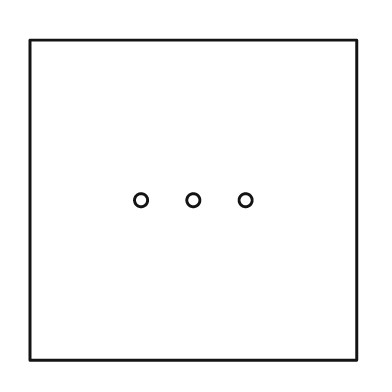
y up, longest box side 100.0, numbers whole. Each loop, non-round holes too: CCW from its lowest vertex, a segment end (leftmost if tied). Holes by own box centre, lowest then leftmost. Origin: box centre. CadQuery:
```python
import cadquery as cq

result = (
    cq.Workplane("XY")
    .moveTo(-50.0, -49.0)
    .lineTo(50.0, -49.0)
    .lineTo(50.0, 49.0)
    .lineTo(-50.0, 49.0)
    .close()
    .moveTo(-16.0, 0.0)
    .circle(2.0)
    .moveTo(0.0, 0.0)
    .circle(2.0)
    .moveTo(16.0, 0.0)
    .circle(2.0)
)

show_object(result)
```